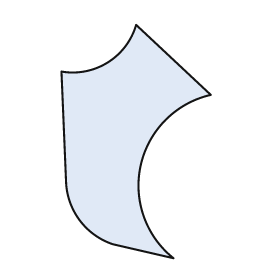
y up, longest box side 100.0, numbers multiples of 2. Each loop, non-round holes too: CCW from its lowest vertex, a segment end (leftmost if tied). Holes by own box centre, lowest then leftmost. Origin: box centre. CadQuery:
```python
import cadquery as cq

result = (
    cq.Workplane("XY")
    .moveTo(16.0, -50.0)
    .threePointArc((2.0, -10.0), (32.0, 20.0))
    .lineTo(0.0, 50.0)
    .threePointArc((-12.0, 34.0), (-32.0, 30.0))
    .lineTo(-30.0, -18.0)
    .threePointArc((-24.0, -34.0), (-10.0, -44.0))
    .close()
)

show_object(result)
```